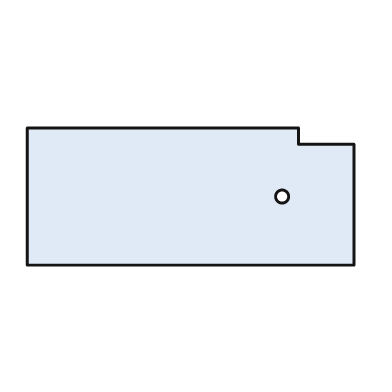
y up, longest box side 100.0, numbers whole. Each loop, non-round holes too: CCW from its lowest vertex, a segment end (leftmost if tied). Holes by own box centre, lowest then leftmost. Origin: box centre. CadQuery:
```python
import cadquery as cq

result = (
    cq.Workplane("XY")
    .moveTo(-50.0, -21.0)
    .lineTo(50.0, -21.0)
    .lineTo(50.0, 16.0)
    .lineTo(33.0, 16.0)
    .lineTo(33.0, 21.0)
    .lineTo(-50.0, 21.0)
    .close()
    .moveTo(28.0, 0.0)
    .circle(2.0)
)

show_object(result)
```